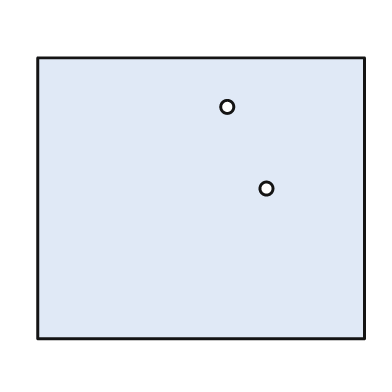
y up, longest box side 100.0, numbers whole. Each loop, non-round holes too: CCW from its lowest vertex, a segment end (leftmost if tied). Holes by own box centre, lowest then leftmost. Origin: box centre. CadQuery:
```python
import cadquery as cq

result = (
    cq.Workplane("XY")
    .moveTo(-50.0, -43.0)
    .lineTo(50.0, -43.0)
    .lineTo(50.0, 43.0)
    .lineTo(-50.0, 43.0)
    .close()
    .moveTo(20.0, 3.0)
    .circle(2.0)
    .moveTo(8.0, 28.0)
    .circle(2.0)
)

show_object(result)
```